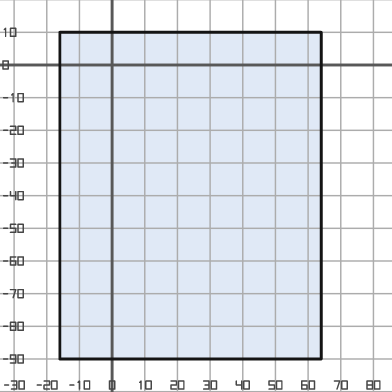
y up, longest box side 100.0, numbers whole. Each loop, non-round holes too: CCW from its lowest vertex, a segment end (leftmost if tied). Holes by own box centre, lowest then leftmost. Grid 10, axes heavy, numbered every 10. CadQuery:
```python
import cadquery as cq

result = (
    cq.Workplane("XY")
    .moveTo(-16.0, -90.0)
    .lineTo(64.0, -90.0)
    .lineTo(64.0, 10.0)
    .lineTo(-16.0, 10.0)
    .close()
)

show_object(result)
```